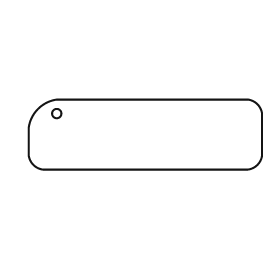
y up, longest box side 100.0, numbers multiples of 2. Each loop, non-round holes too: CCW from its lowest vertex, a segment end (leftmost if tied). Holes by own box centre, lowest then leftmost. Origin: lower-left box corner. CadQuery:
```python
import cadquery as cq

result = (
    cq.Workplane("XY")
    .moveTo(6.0, 0.0)
    .lineTo(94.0, 0.0)
    .threePointArc((98.0, 2.0), (100.0, 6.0))
    .lineTo(100.0, 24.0)
    .threePointArc((98.0, 28.0), (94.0, 30.0))
    .lineTo(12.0, 30.0)
    .threePointArc((4.0, 26.0), (0.0, 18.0))
    .lineTo(0.0, 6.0)
    .threePointArc((2.0, 2.0), (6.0, 0.0))
    .close()
    .moveTo(12.0, 24.0)
    .circle(2.0)
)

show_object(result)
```